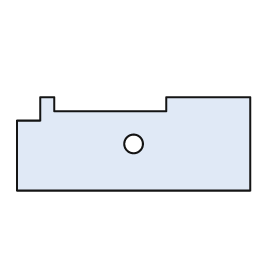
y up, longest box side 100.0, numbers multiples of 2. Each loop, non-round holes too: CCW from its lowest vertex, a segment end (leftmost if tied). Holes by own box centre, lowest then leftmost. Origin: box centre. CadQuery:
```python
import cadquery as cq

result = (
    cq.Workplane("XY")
    .moveTo(-50.0, -20.0)
    .lineTo(50.0, -20.0)
    .lineTo(50.0, 20.0)
    .lineTo(14.0, 20.0)
    .lineTo(14.0, 14.0)
    .lineTo(-34.0, 14.0)
    .lineTo(-34.0, 20.0)
    .lineTo(-40.0, 20.0)
    .lineTo(-40.0, 10.0)
    .lineTo(-50.0, 10.0)
    .close()
    .moveTo(0.0, 0.0)
    .circle(4.0)
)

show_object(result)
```